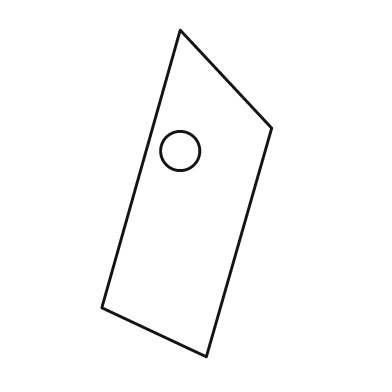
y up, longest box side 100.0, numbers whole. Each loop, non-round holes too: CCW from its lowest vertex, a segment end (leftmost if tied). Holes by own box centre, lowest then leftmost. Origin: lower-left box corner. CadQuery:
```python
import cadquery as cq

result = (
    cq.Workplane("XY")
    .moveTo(32.0, 0.0)
    .lineTo(52.0, 70.0)
    .lineTo(24.0, 100.0)
    .lineTo(0.0, 15.0)
    .close()
    .moveTo(24.0, 63.0)
    .circle(6.0)
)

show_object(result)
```